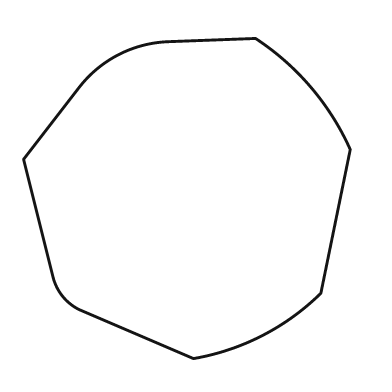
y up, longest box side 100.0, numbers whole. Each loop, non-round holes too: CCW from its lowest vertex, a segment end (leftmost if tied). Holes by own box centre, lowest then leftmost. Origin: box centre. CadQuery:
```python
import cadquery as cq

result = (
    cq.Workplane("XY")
    .moveTo(2.0, -49.0)
    .threePointArc((23.0, -42.0), (41.0, -29.0))
    .lineTo(50.0, 15.0)
    .threePointArc((38.0, 34.0), (21.0, 49.0))
    .lineTo(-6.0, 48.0)
    .threePointArc((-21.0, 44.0), (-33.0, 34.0))
    .lineTo(-50.0, 12.0)
    .lineTo(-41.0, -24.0)
    .threePointArc((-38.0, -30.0), (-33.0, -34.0))
    .close()
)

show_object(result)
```